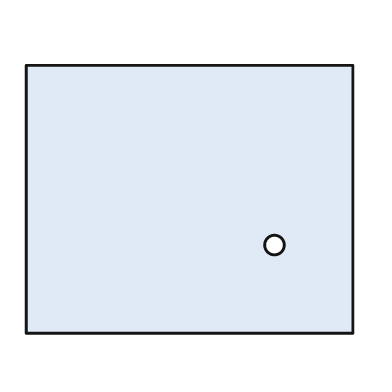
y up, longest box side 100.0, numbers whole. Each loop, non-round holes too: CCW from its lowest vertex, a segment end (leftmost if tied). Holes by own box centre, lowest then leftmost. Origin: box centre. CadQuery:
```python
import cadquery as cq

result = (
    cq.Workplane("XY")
    .moveTo(-50.0, -41.0)
    .lineTo(50.0, -41.0)
    .lineTo(50.0, 41.0)
    .lineTo(-50.0, 41.0)
    .close()
    .moveTo(26.0, -14.0)
    .circle(3.0)
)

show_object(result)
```